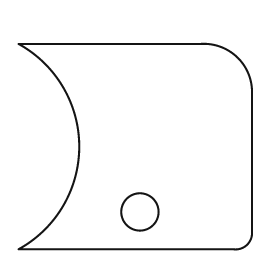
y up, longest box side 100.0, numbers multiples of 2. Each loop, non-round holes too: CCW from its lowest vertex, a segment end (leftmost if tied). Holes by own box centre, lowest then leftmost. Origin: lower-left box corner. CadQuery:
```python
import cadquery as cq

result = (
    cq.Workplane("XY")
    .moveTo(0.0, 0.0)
    .lineTo(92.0, 0.0)
    .threePointArc((98.0, 2.0), (100.0, 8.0))
    .lineTo(100.0, 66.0)
    .threePointArc((94.0, 82.0), (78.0, 88.0))
    .lineTo(0.0, 88.0)
    .threePointArc((26.0, 44.0), (0.0, 0.0))
    .close()
    .moveTo(52.0, 16.0)
    .circle(8.0)
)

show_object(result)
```